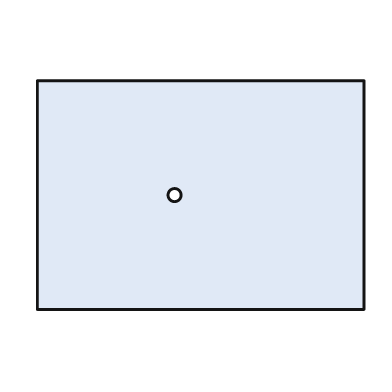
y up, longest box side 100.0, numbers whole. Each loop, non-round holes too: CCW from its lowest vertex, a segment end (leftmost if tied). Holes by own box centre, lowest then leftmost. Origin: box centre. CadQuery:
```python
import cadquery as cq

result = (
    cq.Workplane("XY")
    .moveTo(-50.0, -35.0)
    .lineTo(50.0, -35.0)
    .lineTo(50.0, 35.0)
    .lineTo(-50.0, 35.0)
    .close()
    .moveTo(-8.0, 0.0)
    .circle(2.0)
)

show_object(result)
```